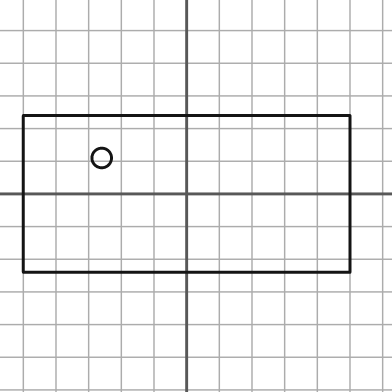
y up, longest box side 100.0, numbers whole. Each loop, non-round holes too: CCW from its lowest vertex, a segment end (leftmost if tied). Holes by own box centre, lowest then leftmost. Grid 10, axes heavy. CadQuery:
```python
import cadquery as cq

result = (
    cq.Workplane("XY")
    .moveTo(-50.0, -24.0)
    .lineTo(50.0, -24.0)
    .lineTo(50.0, 24.0)
    .lineTo(-50.0, 24.0)
    .close()
    .moveTo(-26.0, 11.0)
    .circle(3.0)
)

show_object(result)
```